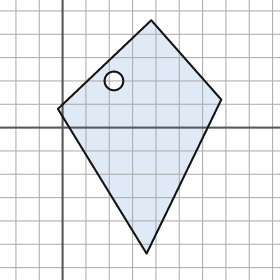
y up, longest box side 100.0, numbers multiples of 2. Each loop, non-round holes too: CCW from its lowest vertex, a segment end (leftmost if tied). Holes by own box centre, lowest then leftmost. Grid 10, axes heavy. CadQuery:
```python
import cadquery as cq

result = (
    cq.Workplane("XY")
    .moveTo(36.0, -54.0)
    .lineTo(68.0, 12.0)
    .lineTo(38.0, 46.0)
    .lineTo(-2.0, 8.0)
    .close()
    .moveTo(22.0, 20.0)
    .circle(4.0)
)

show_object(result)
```